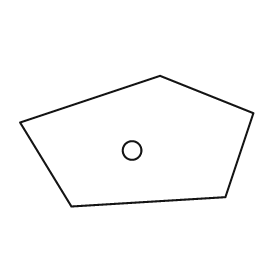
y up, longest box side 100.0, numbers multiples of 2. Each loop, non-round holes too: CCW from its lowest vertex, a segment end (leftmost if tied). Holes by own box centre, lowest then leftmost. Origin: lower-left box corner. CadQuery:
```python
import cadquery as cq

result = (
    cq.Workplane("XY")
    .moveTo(22.0, 0.0)
    .lineTo(88.0, 4.0)
    .lineTo(100.0, 40.0)
    .lineTo(60.0, 56.0)
    .lineTo(0.0, 36.0)
    .close()
    .moveTo(48.0, 24.0)
    .circle(4.0)
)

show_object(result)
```